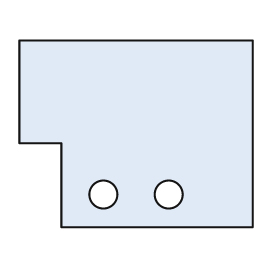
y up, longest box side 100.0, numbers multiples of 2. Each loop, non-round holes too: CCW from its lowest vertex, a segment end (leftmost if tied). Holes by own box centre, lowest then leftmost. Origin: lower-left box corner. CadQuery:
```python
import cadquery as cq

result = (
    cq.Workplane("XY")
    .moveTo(18.0, 0.0)
    .lineTo(100.0, 0.0)
    .lineTo(100.0, 80.0)
    .lineTo(0.0, 80.0)
    .lineTo(0.0, 36.0)
    .lineTo(18.0, 36.0)
    .close()
    .moveTo(36.0, 14.0)
    .circle(6.0)
    .moveTo(64.0, 14.0)
    .circle(6.0)
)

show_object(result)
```